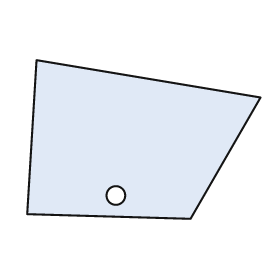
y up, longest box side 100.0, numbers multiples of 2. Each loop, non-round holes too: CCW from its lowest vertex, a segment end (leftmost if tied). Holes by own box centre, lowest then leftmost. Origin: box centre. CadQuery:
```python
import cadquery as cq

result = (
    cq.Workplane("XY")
    .moveTo(20.0, -34.0)
    .lineTo(50.0, 18.0)
    .lineTo(-46.0, 34.0)
    .lineTo(-50.0, -32.0)
    .close()
    .moveTo(-12.0, -24.0)
    .circle(4.0)
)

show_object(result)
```